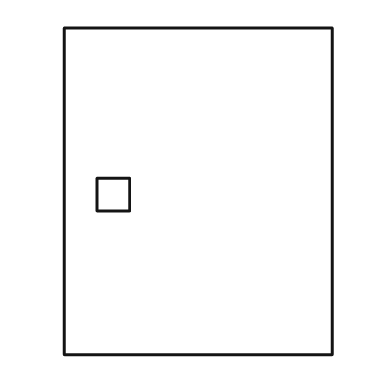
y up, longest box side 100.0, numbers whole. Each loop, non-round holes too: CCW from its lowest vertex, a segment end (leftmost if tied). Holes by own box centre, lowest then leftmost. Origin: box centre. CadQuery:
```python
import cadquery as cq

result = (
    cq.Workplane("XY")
    .moveTo(-41.0, -50.0)
    .lineTo(41.0, -50.0)
    .lineTo(41.0, 50.0)
    .lineTo(-41.0, 50.0)
    .close()
    .moveTo(-31.0, -6.0)
    .lineTo(-21.0, -6.0)
    .lineTo(-21.0, 4.0)
    .lineTo(-31.0, 4.0)
    .close()
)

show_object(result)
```